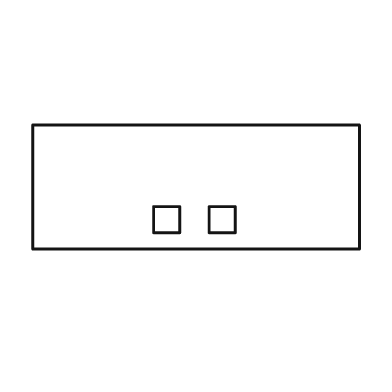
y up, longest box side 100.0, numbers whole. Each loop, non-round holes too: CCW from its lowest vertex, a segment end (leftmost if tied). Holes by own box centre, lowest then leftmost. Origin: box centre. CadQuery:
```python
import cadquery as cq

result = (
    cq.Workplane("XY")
    .moveTo(-50.0, -19.0)
    .lineTo(50.0, -19.0)
    .lineTo(50.0, 19.0)
    .lineTo(-50.0, 19.0)
    .close()
    .moveTo(-13.0, -14.0)
    .lineTo(-5.0, -14.0)
    .lineTo(-5.0, -6.0)
    .lineTo(-13.0, -6.0)
    .close()
    .moveTo(4.0, -14.0)
    .lineTo(12.0, -14.0)
    .lineTo(12.0, -6.0)
    .lineTo(4.0, -6.0)
    .close()
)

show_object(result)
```